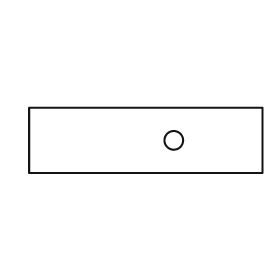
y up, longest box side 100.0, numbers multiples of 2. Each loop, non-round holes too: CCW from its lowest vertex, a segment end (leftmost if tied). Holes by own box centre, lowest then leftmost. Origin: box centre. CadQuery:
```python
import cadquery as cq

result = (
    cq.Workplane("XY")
    .moveTo(-50.0, -14.0)
    .lineTo(50.0, -14.0)
    .lineTo(50.0, 14.0)
    .lineTo(-50.0, 14.0)
    .close()
    .moveTo(12.0, 0.0)
    .circle(4.0)
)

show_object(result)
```